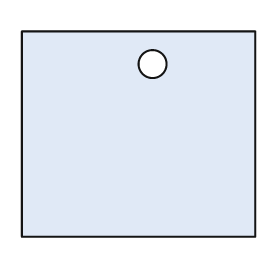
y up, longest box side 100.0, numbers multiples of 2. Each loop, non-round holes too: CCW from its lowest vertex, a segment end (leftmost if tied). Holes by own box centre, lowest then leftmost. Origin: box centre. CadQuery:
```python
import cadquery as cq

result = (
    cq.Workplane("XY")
    .moveTo(-50.0, -44.0)
    .lineTo(50.0, -44.0)
    .lineTo(50.0, 44.0)
    .lineTo(-50.0, 44.0)
    .close()
    .moveTo(6.0, 30.0)
    .circle(6.0)
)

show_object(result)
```